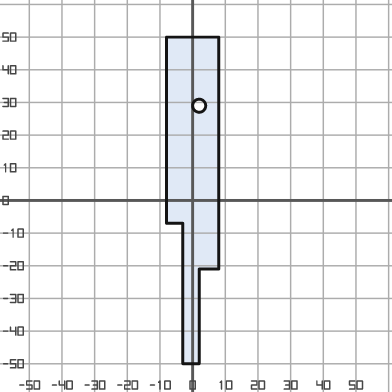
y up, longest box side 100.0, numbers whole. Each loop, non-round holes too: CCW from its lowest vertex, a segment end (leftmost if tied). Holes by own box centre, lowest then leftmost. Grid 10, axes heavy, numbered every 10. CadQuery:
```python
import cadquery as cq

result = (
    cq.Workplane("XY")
    .moveTo(-3.0, -50.0)
    .lineTo(2.0, -50.0)
    .lineTo(2.0, -21.0)
    .lineTo(8.0, -21.0)
    .lineTo(8.0, 50.0)
    .lineTo(-8.0, 50.0)
    .lineTo(-8.0, -7.0)
    .lineTo(-3.0, -7.0)
    .close()
    .moveTo(2.0, 29.0)
    .circle(2.0)
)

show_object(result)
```